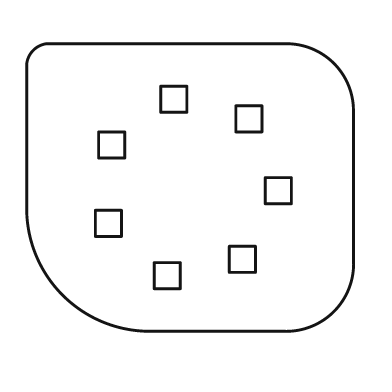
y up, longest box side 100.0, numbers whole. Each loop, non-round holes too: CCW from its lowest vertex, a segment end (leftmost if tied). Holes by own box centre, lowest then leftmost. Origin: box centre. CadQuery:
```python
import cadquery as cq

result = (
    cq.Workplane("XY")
    .moveTo(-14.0, -44.0)
    .lineTo(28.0, -44.0)
    .threePointArc((44.0, -38.0), (50.0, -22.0))
    .lineTo(50.0, 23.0)
    .threePointArc((44.0, 38.0), (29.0, 44.0))
    .lineTo(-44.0, 44.0)
    .threePointArc((-48.0, 42.0), (-50.0, 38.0))
    .lineTo(-50.0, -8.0)
    .threePointArc((-39.0, -33.0), (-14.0, -44.0))
    .close()
    .moveTo(-11.0, -31.0)
    .lineTo(-3.0, -31.0)
    .lineTo(-3.0, -23.0)
    .lineTo(-11.0, -23.0)
    .close()
    .moveTo(12.0, -26.0)
    .lineTo(20.0, -26.0)
    .lineTo(20.0, -18.0)
    .lineTo(12.0, -18.0)
    .close()
    .moveTo(-29.0, -15.0)
    .lineTo(-21.0, -15.0)
    .lineTo(-21.0, -7.0)
    .lineTo(-29.0, -7.0)
    .close()
    .moveTo(23.0, -5.0)
    .lineTo(31.0, -5.0)
    .lineTo(31.0, 3.0)
    .lineTo(23.0, 3.0)
    .close()
    .moveTo(-28.0, 9.0)
    .lineTo(-20.0, 9.0)
    .lineTo(-20.0, 17.0)
    .lineTo(-28.0, 17.0)
    .close()
    .moveTo(14.0, 17.0)
    .lineTo(22.0, 17.0)
    .lineTo(22.0, 25.0)
    .lineTo(14.0, 25.0)
    .close()
    .moveTo(-9.0, 23.0)
    .lineTo(-1.0, 23.0)
    .lineTo(-1.0, 31.0)
    .lineTo(-9.0, 31.0)
    .close()
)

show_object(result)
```